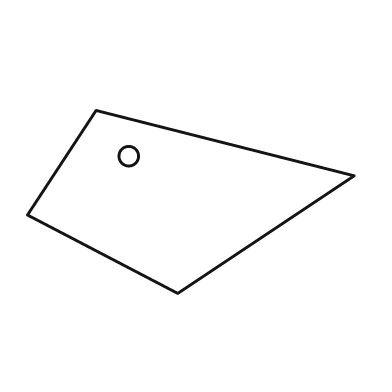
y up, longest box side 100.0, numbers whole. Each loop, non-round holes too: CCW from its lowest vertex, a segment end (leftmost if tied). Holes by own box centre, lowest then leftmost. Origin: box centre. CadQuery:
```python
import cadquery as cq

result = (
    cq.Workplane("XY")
    .moveTo(-4.0, -28.0)
    .lineTo(50.0, 8.0)
    .lineTo(-29.0, 28.0)
    .lineTo(-50.0, -4.0)
    .close()
    .moveTo(-19.0, 14.0)
    .circle(3.0)
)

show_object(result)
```